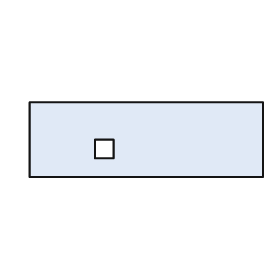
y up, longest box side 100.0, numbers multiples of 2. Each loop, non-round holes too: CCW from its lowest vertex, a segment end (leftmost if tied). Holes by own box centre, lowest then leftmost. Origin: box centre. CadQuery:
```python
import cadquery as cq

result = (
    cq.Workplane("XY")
    .moveTo(-50.0, -16.0)
    .lineTo(50.0, -16.0)
    .lineTo(50.0, 16.0)
    .lineTo(-50.0, 16.0)
    .close()
    .moveTo(-22.0, -8.0)
    .lineTo(-14.0, -8.0)
    .lineTo(-14.0, 0.0)
    .lineTo(-22.0, 0.0)
    .close()
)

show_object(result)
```